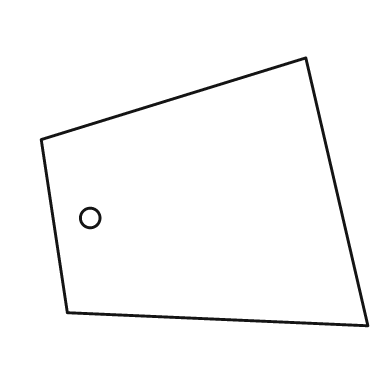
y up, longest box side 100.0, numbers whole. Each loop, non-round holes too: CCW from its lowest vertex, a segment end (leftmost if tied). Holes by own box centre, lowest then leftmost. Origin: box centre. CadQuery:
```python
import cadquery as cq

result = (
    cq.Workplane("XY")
    .moveTo(50.0, -41.0)
    .lineTo(31.0, 41.0)
    .lineTo(-50.0, 16.0)
    .lineTo(-42.0, -37.0)
    .close()
    .moveTo(-35.0, -8.0)
    .circle(3.0)
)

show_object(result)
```